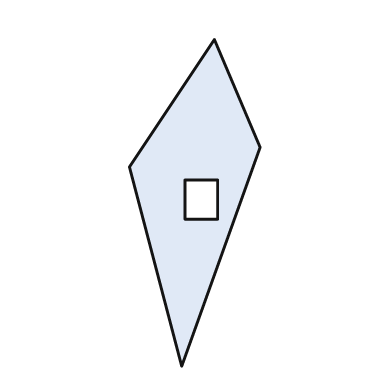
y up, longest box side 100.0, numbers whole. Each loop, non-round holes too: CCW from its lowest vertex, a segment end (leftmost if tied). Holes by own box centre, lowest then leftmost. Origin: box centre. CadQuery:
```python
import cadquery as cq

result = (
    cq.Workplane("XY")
    .moveTo(-4.0, -50.0)
    .lineTo(20.0, 17.0)
    .lineTo(6.0, 50.0)
    .lineTo(-20.0, 11.0)
    .close()
    .moveTo(-3.0, -5.0)
    .lineTo(7.0, -5.0)
    .lineTo(7.0, 7.0)
    .lineTo(-3.0, 7.0)
    .close()
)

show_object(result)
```